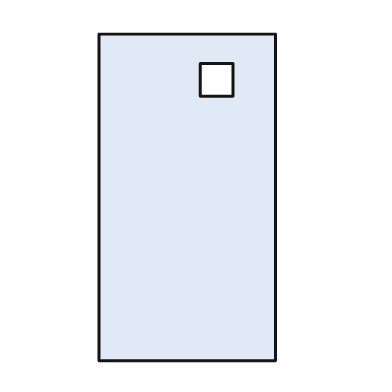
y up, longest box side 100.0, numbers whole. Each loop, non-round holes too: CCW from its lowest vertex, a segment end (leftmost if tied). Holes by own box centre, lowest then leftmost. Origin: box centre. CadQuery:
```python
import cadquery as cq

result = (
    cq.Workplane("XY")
    .moveTo(-27.0, -50.0)
    .lineTo(27.0, -50.0)
    .lineTo(27.0, 50.0)
    .lineTo(-27.0, 50.0)
    .close()
    .moveTo(4.0, 31.0)
    .lineTo(14.0, 31.0)
    .lineTo(14.0, 41.0)
    .lineTo(4.0, 41.0)
    .close()
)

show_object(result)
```